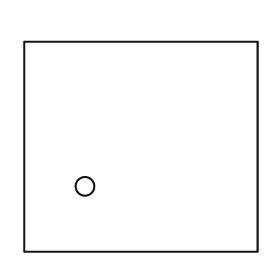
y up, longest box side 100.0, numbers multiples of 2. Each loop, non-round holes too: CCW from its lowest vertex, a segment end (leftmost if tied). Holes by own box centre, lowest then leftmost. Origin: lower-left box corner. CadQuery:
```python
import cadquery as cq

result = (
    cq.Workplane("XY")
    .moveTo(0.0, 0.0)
    .lineTo(100.0, 0.0)
    .lineTo(100.0, 90.0)
    .lineTo(0.0, 90.0)
    .close()
    .moveTo(26.0, 28.0)
    .circle(4.0)
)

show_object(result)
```